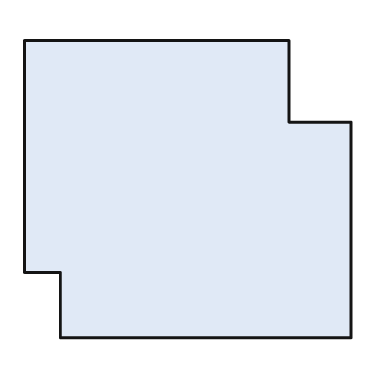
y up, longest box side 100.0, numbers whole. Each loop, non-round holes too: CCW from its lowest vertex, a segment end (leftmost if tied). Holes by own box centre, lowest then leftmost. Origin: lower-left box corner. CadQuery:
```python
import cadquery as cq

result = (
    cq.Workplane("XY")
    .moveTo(11.0, 0.0)
    .lineTo(100.0, 0.0)
    .lineTo(100.0, 66.0)
    .lineTo(81.0, 66.0)
    .lineTo(81.0, 91.0)
    .lineTo(0.0, 91.0)
    .lineTo(0.0, 20.0)
    .lineTo(11.0, 20.0)
    .close()
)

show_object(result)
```